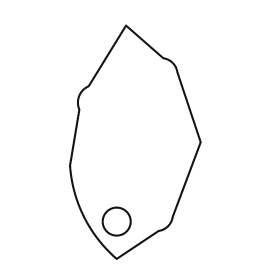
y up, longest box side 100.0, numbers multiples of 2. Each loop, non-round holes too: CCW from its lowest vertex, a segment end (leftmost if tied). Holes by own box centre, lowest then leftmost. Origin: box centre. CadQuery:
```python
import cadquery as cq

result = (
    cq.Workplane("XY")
    .moveTo(-8.0, -50.0)
    .lineTo(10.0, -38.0)
    .threePointArc((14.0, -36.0), (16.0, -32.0))
    .lineTo(28.0, 0.0)
    .lineTo(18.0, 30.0)
    .threePointArc((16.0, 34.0), (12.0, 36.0))
    .lineTo(-4.0, 50.0)
    .lineTo(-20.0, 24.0)
    .threePointArc((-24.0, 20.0), (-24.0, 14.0))
    .lineTo(-28.0, -10.0)
    .threePointArc((-22.0, -32.0), (-8.0, -50.0))
    .close()
    .moveTo(-8.0, -34.0)
    .circle(6.0)
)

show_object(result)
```